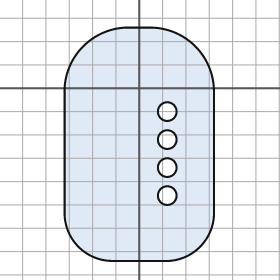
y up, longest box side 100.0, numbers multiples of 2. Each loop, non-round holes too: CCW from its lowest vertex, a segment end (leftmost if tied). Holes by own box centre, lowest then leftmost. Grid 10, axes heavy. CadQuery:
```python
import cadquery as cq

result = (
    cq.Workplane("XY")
    .moveTo(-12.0, -74.0)
    .lineTo(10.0, -74.0)
    .threePointArc((26.0, -68.0), (32.0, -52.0))
    .lineTo(32.0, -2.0)
    .threePointArc((24.0, 18.0), (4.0, 26.0))
    .lineTo(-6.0, 26.0)
    .threePointArc((-24.0, 18.0), (-32.0, 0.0))
    .lineTo(-32.0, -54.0)
    .threePointArc((-26.0, -68.0), (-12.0, -74.0))
    .close()
    .moveTo(12.0, -46.0)
    .circle(4.0)
    .moveTo(12.0, -34.0)
    .circle(4.0)
    .moveTo(12.0, -22.0)
    .circle(4.0)
    .moveTo(12.0, -10.0)
    .circle(4.0)
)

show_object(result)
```